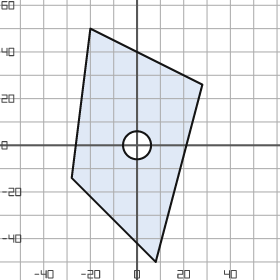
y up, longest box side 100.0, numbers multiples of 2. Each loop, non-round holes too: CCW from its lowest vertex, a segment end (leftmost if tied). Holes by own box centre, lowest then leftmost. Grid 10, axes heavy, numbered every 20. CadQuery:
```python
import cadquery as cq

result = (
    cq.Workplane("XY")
    .moveTo(8.0, -50.0)
    .lineTo(28.0, 26.0)
    .lineTo(-20.0, 50.0)
    .lineTo(-28.0, -14.0)
    .close()
    .moveTo(0.0, 0.0)
    .circle(6.0)
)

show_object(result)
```